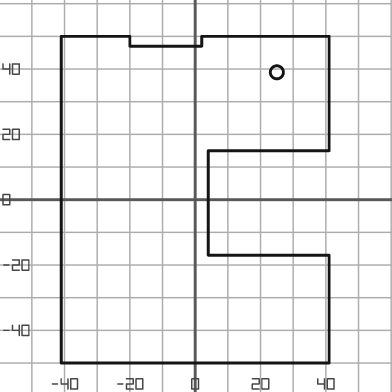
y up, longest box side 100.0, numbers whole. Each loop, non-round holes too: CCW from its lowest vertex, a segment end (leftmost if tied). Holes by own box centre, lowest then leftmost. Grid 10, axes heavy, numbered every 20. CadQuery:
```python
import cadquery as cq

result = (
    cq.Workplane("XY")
    .moveTo(-41.0, -50.0)
    .lineTo(41.0, -50.0)
    .lineTo(41.0, -17.0)
    .lineTo(4.0, -17.0)
    .lineTo(4.0, 15.0)
    .lineTo(41.0, 15.0)
    .lineTo(41.0, 50.0)
    .lineTo(2.0, 50.0)
    .lineTo(2.0, 47.0)
    .lineTo(-20.0, 47.0)
    .lineTo(-20.0, 50.0)
    .lineTo(-41.0, 50.0)
    .close()
    .moveTo(25.0, 39.0)
    .circle(2.0)
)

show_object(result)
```